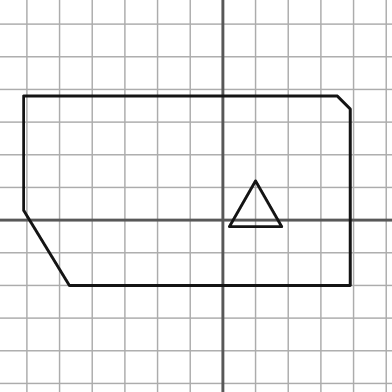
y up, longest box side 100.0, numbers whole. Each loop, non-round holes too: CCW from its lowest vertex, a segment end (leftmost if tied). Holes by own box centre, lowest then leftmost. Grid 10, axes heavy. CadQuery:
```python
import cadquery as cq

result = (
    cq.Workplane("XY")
    .moveTo(-47.0, -20.0)
    .lineTo(39.0, -20.0)
    .lineTo(39.0, 34.0)
    .lineTo(35.0, 38.0)
    .lineTo(-61.0, 38.0)
    .lineTo(-61.0, 3.0)
    .close()
    .moveTo(2.0, -2.0)
    .lineTo(18.0, -2.0)
    .lineTo(10.0, 12.0)
    .close()
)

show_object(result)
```